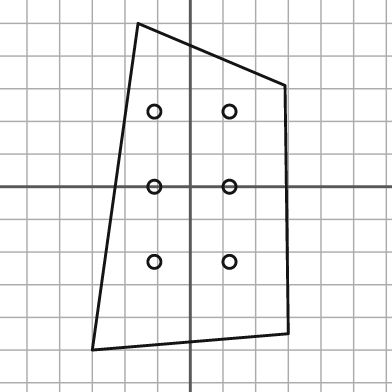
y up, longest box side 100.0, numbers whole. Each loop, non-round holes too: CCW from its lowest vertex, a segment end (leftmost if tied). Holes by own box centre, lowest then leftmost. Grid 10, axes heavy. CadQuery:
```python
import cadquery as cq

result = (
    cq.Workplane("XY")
    .moveTo(-30.0, -50.0)
    .lineTo(30.0, -45.0)
    .lineTo(29.0, 31.0)
    .lineTo(-16.0, 50.0)
    .close()
    .moveTo(-11.0, -23.0)
    .circle(2.0)
    .moveTo(12.0, -23.0)
    .circle(2.0)
    .moveTo(-11.0, 0.0)
    .circle(2.0)
    .moveTo(12.0, 0.0)
    .circle(2.0)
    .moveTo(-11.0, 23.0)
    .circle(2.0)
    .moveTo(12.0, 23.0)
    .circle(2.0)
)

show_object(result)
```